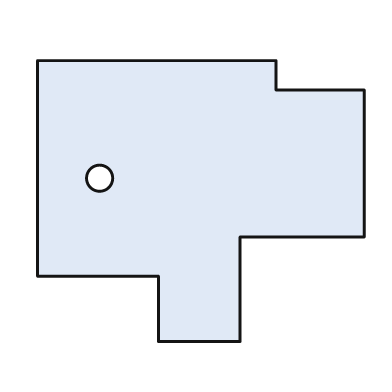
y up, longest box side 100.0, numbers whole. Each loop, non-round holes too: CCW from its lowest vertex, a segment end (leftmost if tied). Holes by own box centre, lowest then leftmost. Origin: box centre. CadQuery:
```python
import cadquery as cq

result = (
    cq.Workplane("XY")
    .moveTo(-13.0, -43.0)
    .lineTo(12.0, -43.0)
    .lineTo(12.0, -11.0)
    .lineTo(50.0, -11.0)
    .lineTo(50.0, 34.0)
    .lineTo(23.0, 34.0)
    .lineTo(23.0, 43.0)
    .lineTo(-50.0, 43.0)
    .lineTo(-50.0, -23.0)
    .lineTo(-13.0, -23.0)
    .close()
    .moveTo(-31.0, 7.0)
    .circle(4.0)
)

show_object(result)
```